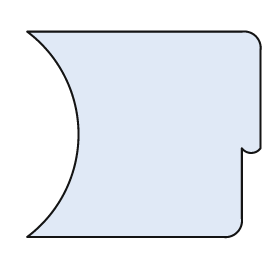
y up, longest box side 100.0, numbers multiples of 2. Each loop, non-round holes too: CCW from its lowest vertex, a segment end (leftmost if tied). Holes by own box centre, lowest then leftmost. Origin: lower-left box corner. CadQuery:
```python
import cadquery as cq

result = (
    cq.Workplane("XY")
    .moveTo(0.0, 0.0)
    .lineTo(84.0, 0.0)
    .threePointArc((90.0, 2.0), (92.0, 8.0))
    .lineTo(92.0, 38.0)
    .threePointArc((96.0, 36.0), (100.0, 38.0))
    .lineTo(100.0, 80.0)
    .threePointArc((98.0, 86.0), (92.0, 88.0))
    .lineTo(0.0, 88.0)
    .threePointArc((22.0, 44.0), (0.0, 0.0))
    .close()
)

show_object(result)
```